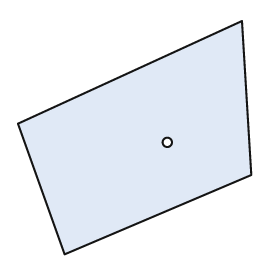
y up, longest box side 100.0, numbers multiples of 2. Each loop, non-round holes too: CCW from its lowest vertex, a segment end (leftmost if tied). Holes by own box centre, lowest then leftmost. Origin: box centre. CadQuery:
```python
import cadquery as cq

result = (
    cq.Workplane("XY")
    .moveTo(-30.0, -50.0)
    .lineTo(50.0, -16.0)
    .lineTo(46.0, 50.0)
    .lineTo(-50.0, 6.0)
    .close()
    .moveTo(14.0, -2.0)
    .circle(2.0)
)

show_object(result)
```